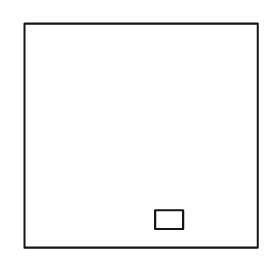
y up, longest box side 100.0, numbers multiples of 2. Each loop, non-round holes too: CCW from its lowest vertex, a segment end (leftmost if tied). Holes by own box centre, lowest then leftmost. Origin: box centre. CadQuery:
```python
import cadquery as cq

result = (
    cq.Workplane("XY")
    .moveTo(-50.0, -48.0)
    .lineTo(50.0, -48.0)
    .lineTo(50.0, 48.0)
    .lineTo(-50.0, 48.0)
    .close()
    .moveTo(6.0, -40.0)
    .lineTo(18.0, -40.0)
    .lineTo(18.0, -32.0)
    .lineTo(6.0, -32.0)
    .close()
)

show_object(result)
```